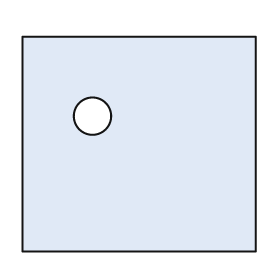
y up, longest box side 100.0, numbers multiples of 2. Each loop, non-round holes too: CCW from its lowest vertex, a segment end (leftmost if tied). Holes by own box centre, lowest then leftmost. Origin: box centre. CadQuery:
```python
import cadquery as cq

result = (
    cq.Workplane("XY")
    .moveTo(-50.0, -46.0)
    .lineTo(50.0, -46.0)
    .lineTo(50.0, 46.0)
    .lineTo(-50.0, 46.0)
    .close()
    .moveTo(-20.0, 12.0)
    .circle(8.0)
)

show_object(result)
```